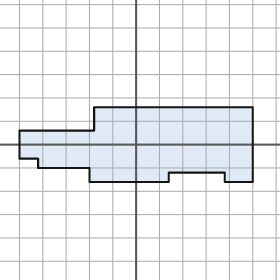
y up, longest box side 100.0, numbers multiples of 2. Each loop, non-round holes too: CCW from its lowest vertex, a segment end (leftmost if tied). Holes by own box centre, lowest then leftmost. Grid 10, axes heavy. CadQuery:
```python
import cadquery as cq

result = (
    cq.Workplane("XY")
    .moveTo(-20.0, -16.0)
    .lineTo(14.0, -16.0)
    .lineTo(14.0, -12.0)
    .lineTo(38.0, -12.0)
    .lineTo(38.0, -16.0)
    .lineTo(50.0, -16.0)
    .lineTo(50.0, 16.0)
    .lineTo(-18.0, 16.0)
    .lineTo(-18.0, 6.0)
    .lineTo(-50.0, 6.0)
    .lineTo(-50.0, -6.0)
    .lineTo(-42.0, -6.0)
    .lineTo(-42.0, -10.0)
    .lineTo(-20.0, -10.0)
    .close()
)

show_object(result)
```